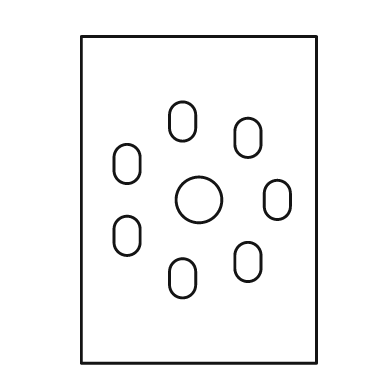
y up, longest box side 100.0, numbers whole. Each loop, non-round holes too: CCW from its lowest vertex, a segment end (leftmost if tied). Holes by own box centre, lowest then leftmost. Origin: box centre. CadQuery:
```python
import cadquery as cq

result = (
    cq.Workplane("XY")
    .moveTo(-36.0, -50.0)
    .lineTo(36.0, -50.0)
    .lineTo(36.0, 50.0)
    .lineTo(-36.0, 50.0)
    .close()
    .moveTo(-9.0, -26.0)
    .threePointArc((-5.0, -30.0), (-1.0, -26.0))
    .lineTo(-1.0, -22.0)
    .threePointArc((-5.0, -18.0), (-9.0, -22.0))
    .close()
    .moveTo(11.0, -21.0)
    .threePointArc((15.0, -25.0), (19.0, -21.0))
    .lineTo(19.0, -17.0)
    .threePointArc((15.0, -13.0), (11.0, -17.0))
    .close()
    .moveTo(-26.0, -13.0)
    .threePointArc((-22.0, -17.0), (-18.0, -13.0))
    .lineTo(-18.0, -9.0)
    .threePointArc((-22.0, -5.0), (-26.0, -9.0))
    .close()
    .moveTo(0.0, 0.0)
    .circle(7.0)
    .moveTo(20.0, -2.0)
    .threePointArc((24.0, -6.0), (28.0, -2.0))
    .lineTo(28.0, 2.0)
    .threePointArc((24.0, 6.0), (20.0, 2.0))
    .close()
    .moveTo(-26.0, 9.0)
    .threePointArc((-22.0, 5.0), (-18.0, 9.0))
    .lineTo(-18.0, 13.0)
    .threePointArc((-22.0, 17.0), (-26.0, 13.0))
    .close()
    .moveTo(11.0, 17.0)
    .threePointArc((15.0, 13.0), (19.0, 17.0))
    .lineTo(19.0, 21.0)
    .threePointArc((15.0, 25.0), (11.0, 21.0))
    .close()
    .moveTo(-9.0, 22.0)
    .threePointArc((-5.0, 18.0), (-1.0, 22.0))
    .lineTo(-1.0, 26.0)
    .threePointArc((-5.0, 30.0), (-9.0, 26.0))
    .close()
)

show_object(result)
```